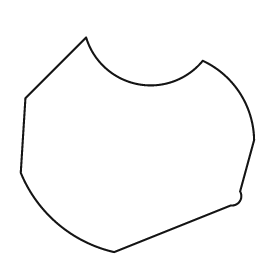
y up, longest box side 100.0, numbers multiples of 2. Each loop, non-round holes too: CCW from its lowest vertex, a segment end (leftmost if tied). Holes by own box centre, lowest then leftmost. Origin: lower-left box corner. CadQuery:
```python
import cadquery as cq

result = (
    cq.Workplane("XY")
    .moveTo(40.0, 0.0)
    .lineTo(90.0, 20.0)
    .threePointArc((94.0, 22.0), (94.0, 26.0))
    .lineTo(100.0, 48.0)
    .threePointArc((94.0, 68.0), (78.0, 82.0))
    .threePointArc((50.0, 72.0), (28.0, 92.0))
    .lineTo(2.0, 66.0)
    .lineTo(0.0, 34.0)
    .threePointArc((16.0, 12.0), (40.0, 0.0))
    .close()
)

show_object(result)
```